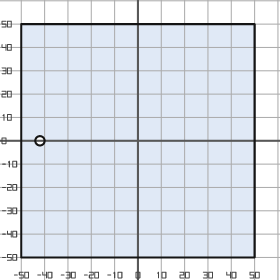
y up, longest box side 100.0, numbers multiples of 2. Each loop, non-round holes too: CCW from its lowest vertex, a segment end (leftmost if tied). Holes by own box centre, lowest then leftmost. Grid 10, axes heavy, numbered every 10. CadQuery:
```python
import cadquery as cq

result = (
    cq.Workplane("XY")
    .moveTo(-50.0, -50.0)
    .lineTo(50.0, -50.0)
    .lineTo(50.0, 50.0)
    .lineTo(-50.0, 50.0)
    .close()
    .moveTo(-42.0, 0.0)
    .circle(2.0)
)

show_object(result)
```